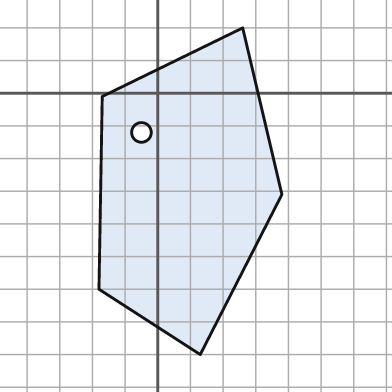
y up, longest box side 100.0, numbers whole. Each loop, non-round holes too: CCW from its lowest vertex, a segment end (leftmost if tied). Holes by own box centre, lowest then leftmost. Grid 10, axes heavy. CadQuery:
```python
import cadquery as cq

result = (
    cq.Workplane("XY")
    .moveTo(13.0, -80.0)
    .lineTo(38.0, -31.0)
    .lineTo(26.0, 20.0)
    .lineTo(-17.0, -1.0)
    .lineTo(-18.0, -60.0)
    .close()
    .moveTo(-5.0, -12.0)
    .circle(3.0)
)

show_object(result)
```